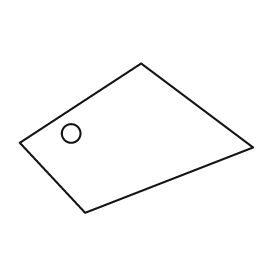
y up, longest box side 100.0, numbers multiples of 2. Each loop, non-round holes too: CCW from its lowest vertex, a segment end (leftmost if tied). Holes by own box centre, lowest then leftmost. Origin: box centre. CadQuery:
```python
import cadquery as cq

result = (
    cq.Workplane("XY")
    .moveTo(-22.0, -32.0)
    .lineTo(50.0, -4.0)
    .lineTo(2.0, 32.0)
    .lineTo(-50.0, -2.0)
    .close()
    .moveTo(-28.0, 2.0)
    .circle(4.0)
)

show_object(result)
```